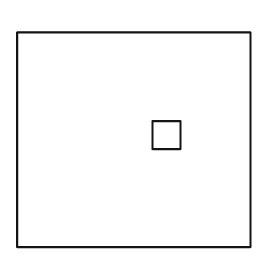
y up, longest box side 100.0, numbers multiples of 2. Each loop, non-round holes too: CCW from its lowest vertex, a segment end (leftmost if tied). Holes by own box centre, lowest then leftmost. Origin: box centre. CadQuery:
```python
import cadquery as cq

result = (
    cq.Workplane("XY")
    .moveTo(-50.0, -46.0)
    .lineTo(50.0, -46.0)
    .lineTo(50.0, 46.0)
    .lineTo(-50.0, 46.0)
    .close()
    .moveTo(8.0, -4.0)
    .lineTo(20.0, -4.0)
    .lineTo(20.0, 8.0)
    .lineTo(8.0, 8.0)
    .close()
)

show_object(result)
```